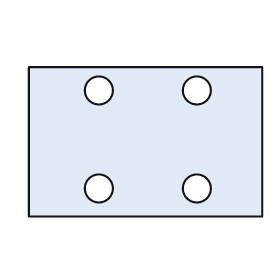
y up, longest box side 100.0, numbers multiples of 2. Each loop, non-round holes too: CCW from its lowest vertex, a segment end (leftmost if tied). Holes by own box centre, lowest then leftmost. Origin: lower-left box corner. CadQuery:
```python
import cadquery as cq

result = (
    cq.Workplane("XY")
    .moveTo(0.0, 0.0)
    .lineTo(100.0, 0.0)
    .lineTo(100.0, 64.0)
    .lineTo(0.0, 64.0)
    .close()
    .moveTo(30.0, 12.0)
    .circle(6.0)
    .moveTo(72.0, 12.0)
    .circle(6.0)
    .moveTo(30.0, 54.0)
    .circle(6.0)
    .moveTo(72.0, 54.0)
    .circle(6.0)
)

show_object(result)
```